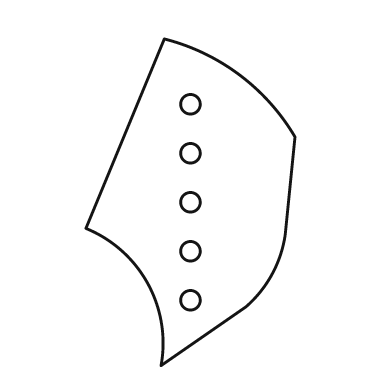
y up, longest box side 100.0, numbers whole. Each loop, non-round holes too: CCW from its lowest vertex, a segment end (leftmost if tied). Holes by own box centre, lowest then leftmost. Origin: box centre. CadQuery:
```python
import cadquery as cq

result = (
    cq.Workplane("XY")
    .moveTo(-9.0, -50.0)
    .lineTo(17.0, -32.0)
    .threePointArc((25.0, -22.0), (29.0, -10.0))
    .lineTo(32.0, 20.0)
    .threePointArc((15.0, 39.0), (-8.0, 50.0))
    .lineTo(-32.0, -8.0)
    .threePointArc((-13.0, -25.0), (-9.0, -50.0))
    .close()
    .moveTo(0.0, -30.0)
    .circle(3.0)
    .moveTo(0.0, -15.0)
    .circle(3.0)
    .moveTo(0.0, 0.0)
    .circle(3.0)
    .moveTo(0.0, 15.0)
    .circle(3.0)
    .moveTo(0.0, 30.0)
    .circle(3.0)
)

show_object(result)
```